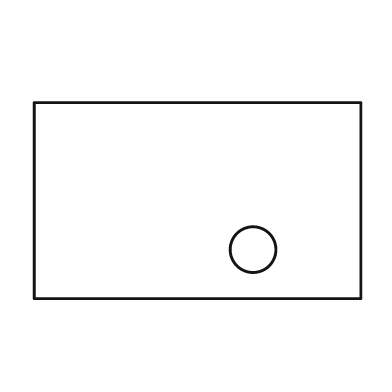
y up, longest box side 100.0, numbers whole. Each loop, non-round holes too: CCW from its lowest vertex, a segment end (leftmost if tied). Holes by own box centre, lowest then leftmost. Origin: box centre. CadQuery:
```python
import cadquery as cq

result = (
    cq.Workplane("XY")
    .moveTo(-50.0, -30.0)
    .lineTo(50.0, -30.0)
    .lineTo(50.0, 30.0)
    .lineTo(-50.0, 30.0)
    .close()
    .moveTo(17.0, -15.0)
    .circle(7.0)
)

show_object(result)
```